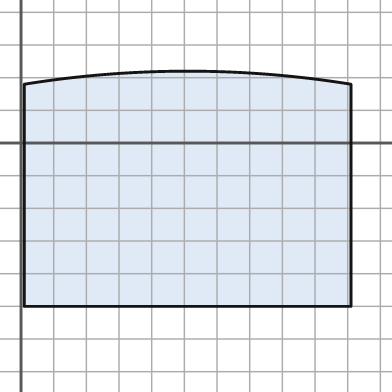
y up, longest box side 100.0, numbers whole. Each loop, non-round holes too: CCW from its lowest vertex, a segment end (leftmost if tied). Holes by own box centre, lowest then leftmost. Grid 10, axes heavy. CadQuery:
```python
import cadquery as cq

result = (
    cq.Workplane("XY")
    .moveTo(1.0, -50.0)
    .lineTo(101.0, -50.0)
    .lineTo(101.0, 18.0)
    .threePointArc((51.0, 22.0), (1.0, 18.0))
    .close()
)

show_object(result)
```